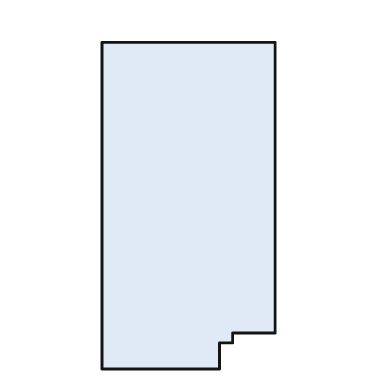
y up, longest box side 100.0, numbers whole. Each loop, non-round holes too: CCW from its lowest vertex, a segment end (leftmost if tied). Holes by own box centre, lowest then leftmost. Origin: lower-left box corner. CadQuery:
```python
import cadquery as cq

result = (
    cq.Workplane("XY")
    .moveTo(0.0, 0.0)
    .lineTo(36.0, 0.0)
    .lineTo(36.0, 8.0)
    .lineTo(40.0, 8.0)
    .lineTo(40.0, 11.0)
    .lineTo(53.0, 11.0)
    .lineTo(53.0, 100.0)
    .lineTo(0.0, 100.0)
    .close()
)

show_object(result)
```